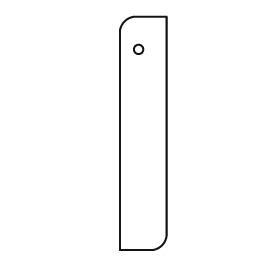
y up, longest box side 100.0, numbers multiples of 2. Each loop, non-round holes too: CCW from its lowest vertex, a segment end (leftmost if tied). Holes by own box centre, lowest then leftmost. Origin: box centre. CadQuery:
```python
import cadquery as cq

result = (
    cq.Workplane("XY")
    .moveTo(-10.0, -50.0)
    .lineTo(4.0, -50.0)
    .threePointArc((8.0, -48.0), (10.0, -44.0))
    .lineTo(10.0, 50.0)
    .lineTo(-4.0, 50.0)
    .threePointArc((-8.0, 48.0), (-10.0, 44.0))
    .close()
    .moveTo(-2.0, 36.0)
    .circle(2.0)
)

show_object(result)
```